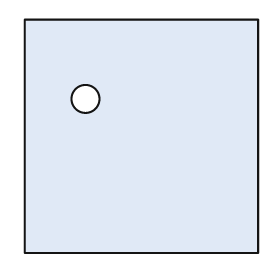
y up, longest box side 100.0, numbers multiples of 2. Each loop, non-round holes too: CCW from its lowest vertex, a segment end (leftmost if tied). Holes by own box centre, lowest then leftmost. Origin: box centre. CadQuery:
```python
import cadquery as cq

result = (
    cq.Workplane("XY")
    .moveTo(-50.0, -50.0)
    .lineTo(50.0, -50.0)
    .lineTo(50.0, 50.0)
    .lineTo(-50.0, 50.0)
    .close()
    .moveTo(-24.0, 16.0)
    .circle(6.0)
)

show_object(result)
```